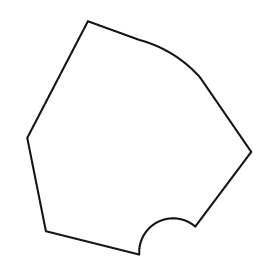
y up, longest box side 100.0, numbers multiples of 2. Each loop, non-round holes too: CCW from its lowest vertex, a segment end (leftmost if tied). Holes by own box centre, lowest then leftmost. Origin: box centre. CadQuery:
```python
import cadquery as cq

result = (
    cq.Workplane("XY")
    .moveTo(0.0, -50.0)
    .threePointArc((8.0, -36.0), (24.0, -38.0))
    .lineTo(48.0, -6.0)
    .lineTo(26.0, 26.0)
    .threePointArc((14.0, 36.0), (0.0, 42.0))
    .lineTo(-22.0, 50.0)
    .lineTo(-48.0, 0.0)
    .lineTo(-40.0, -40.0)
    .close()
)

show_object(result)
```